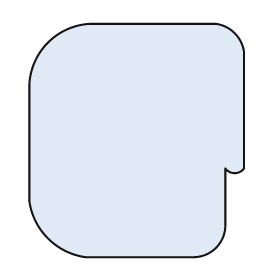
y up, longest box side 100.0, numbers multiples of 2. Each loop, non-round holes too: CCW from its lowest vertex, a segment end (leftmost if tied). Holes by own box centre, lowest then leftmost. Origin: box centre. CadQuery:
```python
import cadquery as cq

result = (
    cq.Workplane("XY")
    .moveTo(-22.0, -50.0)
    .lineTo(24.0, -50.0)
    .threePointArc((34.0, -46.0), (38.0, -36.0))
    .lineTo(38.0, -12.0)
    .threePointArc((42.0, -14.0), (46.0, -12.0))
    .lineTo(46.0, 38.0)
    .threePointArc((42.0, 46.0), (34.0, 50.0))
    .lineTo(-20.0, 50.0)
    .threePointArc((-38.0, 42.0), (-46.0, 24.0))
    .lineTo(-46.0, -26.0)
    .threePointArc((-38.0, -42.0), (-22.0, -50.0))
    .close()
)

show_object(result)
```